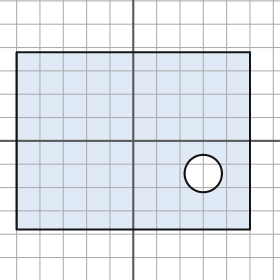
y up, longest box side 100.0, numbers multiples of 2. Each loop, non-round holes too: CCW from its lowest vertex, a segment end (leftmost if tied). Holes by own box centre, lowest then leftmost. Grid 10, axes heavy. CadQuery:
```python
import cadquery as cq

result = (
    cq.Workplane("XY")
    .moveTo(-50.0, -38.0)
    .lineTo(50.0, -38.0)
    .lineTo(50.0, 38.0)
    .lineTo(-50.0, 38.0)
    .close()
    .moveTo(30.0, -14.0)
    .circle(8.0)
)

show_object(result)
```